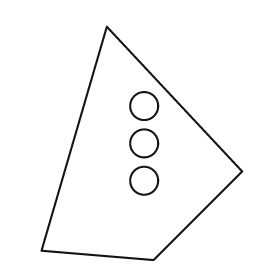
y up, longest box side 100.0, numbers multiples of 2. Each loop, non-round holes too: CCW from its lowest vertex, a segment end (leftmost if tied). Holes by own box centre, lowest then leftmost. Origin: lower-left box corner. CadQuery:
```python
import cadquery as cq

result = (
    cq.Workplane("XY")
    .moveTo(48.0, 0.0)
    .lineTo(86.0, 38.0)
    .lineTo(28.0, 100.0)
    .lineTo(0.0, 4.0)
    .close()
    .moveTo(44.0, 34.0)
    .circle(6.0)
    .moveTo(44.0, 50.0)
    .circle(6.0)
    .moveTo(44.0, 66.0)
    .circle(6.0)
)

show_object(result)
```